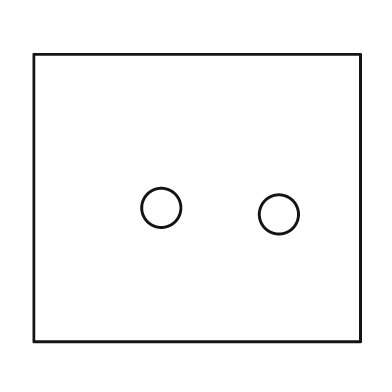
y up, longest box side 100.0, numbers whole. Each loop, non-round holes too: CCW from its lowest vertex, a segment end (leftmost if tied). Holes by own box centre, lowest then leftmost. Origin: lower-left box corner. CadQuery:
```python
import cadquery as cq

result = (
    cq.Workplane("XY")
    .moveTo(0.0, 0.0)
    .lineTo(100.0, 0.0)
    .lineTo(100.0, 88.0)
    .lineTo(0.0, 88.0)
    .close()
    .moveTo(75.0, 39.0)
    .circle(6.0)
    .moveTo(39.0, 41.0)
    .circle(6.0)
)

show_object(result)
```